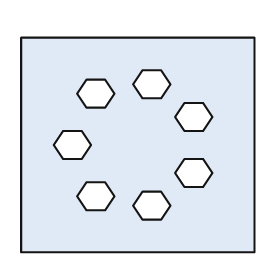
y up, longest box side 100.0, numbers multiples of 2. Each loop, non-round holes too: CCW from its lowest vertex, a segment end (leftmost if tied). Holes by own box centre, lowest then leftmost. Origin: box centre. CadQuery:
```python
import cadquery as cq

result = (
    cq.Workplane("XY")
    .moveTo(-50.0, -46.0)
    .lineTo(50.0, -46.0)
    .lineTo(50.0, 46.0)
    .lineTo(-50.0, 46.0)
    .close()
    .moveTo(2.0, -32.0)
    .lineTo(10.0, -32.0)
    .lineTo(14.0, -26.0)
    .lineTo(10.0, -20.0)
    .lineTo(2.0, -20.0)
    .lineTo(-2.0, -26.0)
    .close()
    .moveTo(-22.0, -28.0)
    .lineTo(-14.0, -28.0)
    .lineTo(-10.0, -22.0)
    .lineTo(-14.0, -16.0)
    .lineTo(-22.0, -16.0)
    .lineTo(-26.0, -22.0)
    .close()
    .moveTo(20.0, -18.0)
    .lineTo(28.0, -18.0)
    .lineTo(32.0, -12.0)
    .lineTo(28.0, -6.0)
    .lineTo(20.0, -6.0)
    .lineTo(16.0, -12.0)
    .close()
    .moveTo(-32.0, -6.0)
    .lineTo(-24.0, -6.0)
    .lineTo(-20.0, 0.0)
    .lineTo(-24.0, 6.0)
    .lineTo(-32.0, 6.0)
    .lineTo(-36.0, 0.0)
    .close()
    .moveTo(20.0, 6.0)
    .lineTo(28.0, 6.0)
    .lineTo(32.0, 12.0)
    .lineTo(28.0, 18.0)
    .lineTo(20.0, 18.0)
    .lineTo(16.0, 12.0)
    .close()
    .moveTo(-22.0, 16.0)
    .lineTo(-14.0, 16.0)
    .lineTo(-10.0, 22.0)
    .lineTo(-14.0, 28.0)
    .lineTo(-22.0, 28.0)
    .lineTo(-26.0, 22.0)
    .close()
    .moveTo(2.0, 20.0)
    .lineTo(10.0, 20.0)
    .lineTo(14.0, 26.0)
    .lineTo(10.0, 32.0)
    .lineTo(2.0, 32.0)
    .lineTo(-2.0, 26.0)
    .close()
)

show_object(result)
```